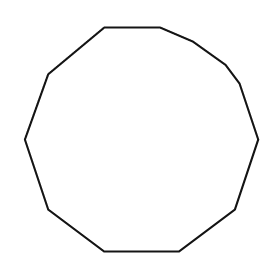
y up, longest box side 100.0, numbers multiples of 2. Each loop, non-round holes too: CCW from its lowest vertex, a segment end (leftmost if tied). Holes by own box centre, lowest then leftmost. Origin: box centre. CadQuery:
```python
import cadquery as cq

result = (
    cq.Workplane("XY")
    .moveTo(-16.0, -48.0)
    .lineTo(16.0, -48.0)
    .lineTo(40.0, -30.0)
    .lineTo(50.0, 0.0)
    .lineTo(42.0, 24.0)
    .lineTo(36.0, 32.0)
    .lineTo(22.0, 42.0)
    .lineTo(8.0, 48.0)
    .lineTo(-16.0, 48.0)
    .lineTo(-40.0, 28.0)
    .lineTo(-50.0, 0.0)
    .lineTo(-40.0, -30.0)
    .close()
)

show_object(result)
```